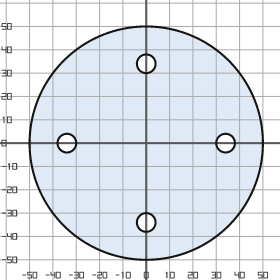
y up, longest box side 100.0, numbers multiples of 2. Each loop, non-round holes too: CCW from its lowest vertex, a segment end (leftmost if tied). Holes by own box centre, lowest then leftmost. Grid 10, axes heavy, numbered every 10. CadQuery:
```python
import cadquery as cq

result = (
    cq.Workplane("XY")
    .moveTo(0.0, 0.0)
    .circle(50.0)
    .moveTo(0.0, -34.0)
    .circle(4.0)
    .moveTo(-34.0, 0.0)
    .circle(4.0)
    .moveTo(34.0, 0.0)
    .circle(4.0)
    .moveTo(0.0, 34.0)
    .circle(4.0)
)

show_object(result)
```